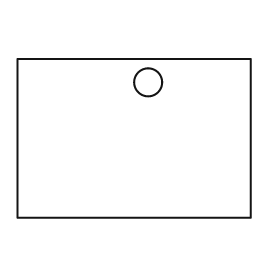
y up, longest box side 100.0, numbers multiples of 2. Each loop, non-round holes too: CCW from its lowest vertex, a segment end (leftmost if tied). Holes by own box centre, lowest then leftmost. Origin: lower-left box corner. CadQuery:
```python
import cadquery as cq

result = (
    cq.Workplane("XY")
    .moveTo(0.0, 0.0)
    .lineTo(100.0, 0.0)
    .lineTo(100.0, 68.0)
    .lineTo(0.0, 68.0)
    .close()
    .moveTo(56.0, 58.0)
    .circle(6.0)
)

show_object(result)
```